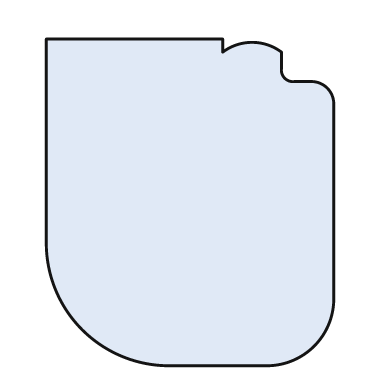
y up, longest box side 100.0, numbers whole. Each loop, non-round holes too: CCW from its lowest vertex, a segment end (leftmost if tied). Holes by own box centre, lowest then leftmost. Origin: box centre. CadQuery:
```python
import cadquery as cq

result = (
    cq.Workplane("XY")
    .moveTo(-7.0, -50.0)
    .lineTo(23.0, -50.0)
    .threePointArc((38.0, -44.0), (44.0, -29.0))
    .lineTo(44.0, 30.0)
    .threePointArc((42.0, 35.0), (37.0, 37.0))
    .lineTo(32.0, 37.0)
    .threePointArc((29.0, 38.0), (28.0, 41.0))
    .lineTo(28.0, 46.0)
    .threePointArc((19.0, 49.0), (10.0, 46.0))
    .lineTo(10.0, 50.0)
    .lineTo(-44.0, 50.0)
    .lineTo(-44.0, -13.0)
    .threePointArc((-33.0, -39.0), (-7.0, -50.0))
    .close()
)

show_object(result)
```